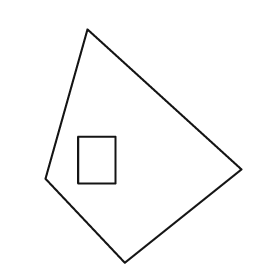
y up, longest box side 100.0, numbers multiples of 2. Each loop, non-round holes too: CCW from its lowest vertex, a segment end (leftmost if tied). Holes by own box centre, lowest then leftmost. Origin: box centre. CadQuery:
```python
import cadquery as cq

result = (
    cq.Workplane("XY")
    .moveTo(-8.0, -50.0)
    .lineTo(42.0, -10.0)
    .lineTo(-24.0, 50.0)
    .lineTo(-42.0, -14.0)
    .close()
    .moveTo(-28.0, -16.0)
    .lineTo(-12.0, -16.0)
    .lineTo(-12.0, 4.0)
    .lineTo(-28.0, 4.0)
    .close()
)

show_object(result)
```